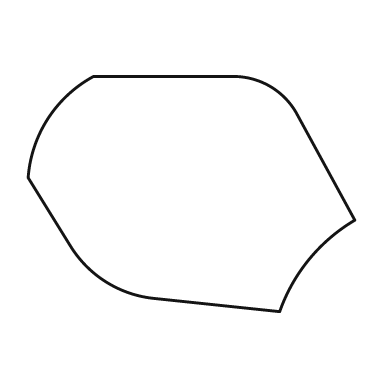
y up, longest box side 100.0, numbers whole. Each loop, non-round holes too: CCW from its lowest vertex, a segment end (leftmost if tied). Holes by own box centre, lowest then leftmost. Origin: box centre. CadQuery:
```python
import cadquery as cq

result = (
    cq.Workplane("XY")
    .moveTo(27.0, -36.0)
    .threePointArc((36.0, -20.0), (50.0, -8.0))
    .lineTo(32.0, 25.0)
    .threePointArc((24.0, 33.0), (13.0, 36.0))
    .lineTo(-30.0, 36.0)
    .threePointArc((-44.0, 23.0), (-50.0, 5.0))
    .lineTo(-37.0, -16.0)
    .threePointArc((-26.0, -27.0), (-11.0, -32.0))
    .close()
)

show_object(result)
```